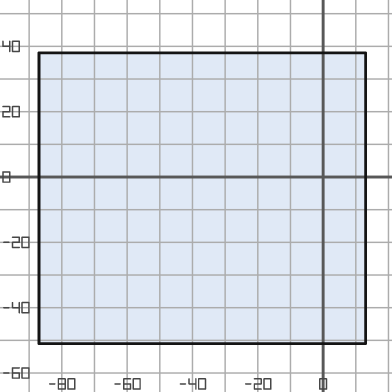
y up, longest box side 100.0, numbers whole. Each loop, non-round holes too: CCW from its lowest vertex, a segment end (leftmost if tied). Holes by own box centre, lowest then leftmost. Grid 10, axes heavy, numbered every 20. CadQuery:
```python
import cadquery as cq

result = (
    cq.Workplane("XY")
    .moveTo(-87.0, -51.0)
    .lineTo(13.0, -51.0)
    .lineTo(13.0, 38.0)
    .lineTo(-87.0, 38.0)
    .close()
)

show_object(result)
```